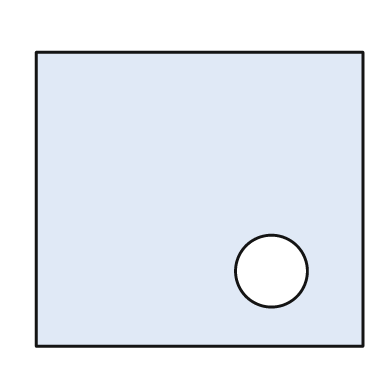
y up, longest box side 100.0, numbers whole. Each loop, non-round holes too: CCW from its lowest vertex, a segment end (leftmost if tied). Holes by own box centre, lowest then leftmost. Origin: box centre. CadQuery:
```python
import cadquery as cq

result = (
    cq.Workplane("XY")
    .moveTo(-50.0, -45.0)
    .lineTo(50.0, -45.0)
    .lineTo(50.0, 45.0)
    .lineTo(-50.0, 45.0)
    .close()
    .moveTo(22.0, -22.0)
    .circle(11.0)
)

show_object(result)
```